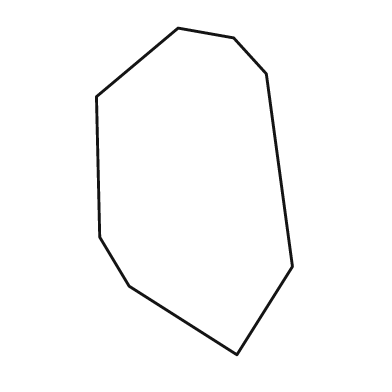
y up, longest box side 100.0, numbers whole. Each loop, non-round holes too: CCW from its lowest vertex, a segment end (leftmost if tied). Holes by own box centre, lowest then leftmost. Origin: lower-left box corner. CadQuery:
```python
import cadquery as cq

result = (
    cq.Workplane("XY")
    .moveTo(43.0, 0.0)
    .lineTo(60.0, 27.0)
    .lineTo(52.0, 86.0)
    .lineTo(42.0, 97.0)
    .lineTo(25.0, 100.0)
    .lineTo(0.0, 79.0)
    .lineTo(1.0, 36.0)
    .lineTo(10.0, 21.0)
    .close()
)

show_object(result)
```